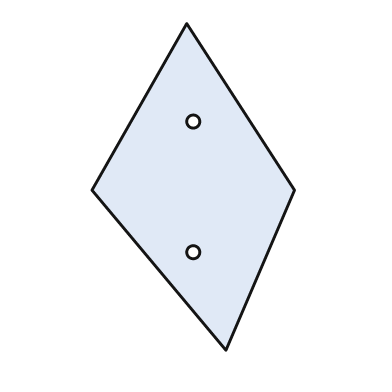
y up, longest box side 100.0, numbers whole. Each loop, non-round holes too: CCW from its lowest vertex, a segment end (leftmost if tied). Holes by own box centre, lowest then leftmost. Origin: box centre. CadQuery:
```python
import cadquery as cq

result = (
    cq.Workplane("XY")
    .moveTo(10.0, -50.0)
    .lineTo(31.0, -1.0)
    .lineTo(-2.0, 50.0)
    .lineTo(-31.0, -1.0)
    .close()
    .moveTo(0.0, -20.0)
    .circle(2.0)
    .moveTo(0.0, 20.0)
    .circle(2.0)
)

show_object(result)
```